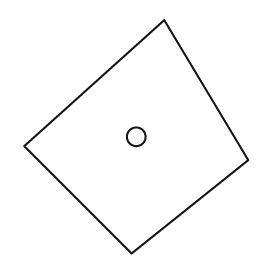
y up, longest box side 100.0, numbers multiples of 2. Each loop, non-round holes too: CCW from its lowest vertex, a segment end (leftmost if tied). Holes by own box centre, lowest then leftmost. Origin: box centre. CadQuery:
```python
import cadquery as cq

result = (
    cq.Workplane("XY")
    .moveTo(-2.0, -50.0)
    .lineTo(48.0, -10.0)
    .lineTo(12.0, 50.0)
    .lineTo(-48.0, -4.0)
    .close()
    .moveTo(0.0, 0.0)
    .circle(4.0)
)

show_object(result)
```